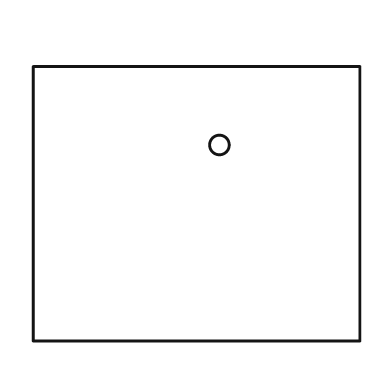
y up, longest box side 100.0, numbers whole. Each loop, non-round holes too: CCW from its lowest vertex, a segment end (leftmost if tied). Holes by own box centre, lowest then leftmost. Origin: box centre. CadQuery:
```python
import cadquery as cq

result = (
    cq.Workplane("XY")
    .moveTo(-50.0, -42.0)
    .lineTo(50.0, -42.0)
    .lineTo(50.0, 42.0)
    .lineTo(-50.0, 42.0)
    .close()
    .moveTo(7.0, 18.0)
    .circle(3.0)
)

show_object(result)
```